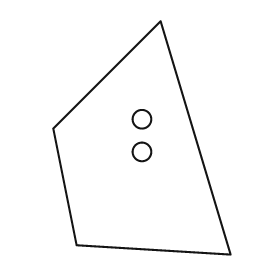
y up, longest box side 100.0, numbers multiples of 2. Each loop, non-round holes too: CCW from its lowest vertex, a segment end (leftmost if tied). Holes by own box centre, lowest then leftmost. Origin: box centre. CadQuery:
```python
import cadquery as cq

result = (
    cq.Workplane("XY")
    .moveTo(38.0, -50.0)
    .lineTo(8.0, 50.0)
    .lineTo(-38.0, 4.0)
    .lineTo(-28.0, -46.0)
    .close()
    .moveTo(0.0, -6.0)
    .circle(4.0)
    .moveTo(0.0, 8.0)
    .circle(4.0)
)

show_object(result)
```